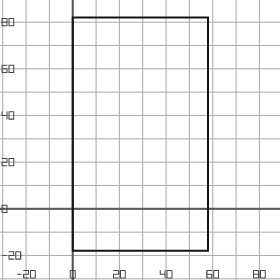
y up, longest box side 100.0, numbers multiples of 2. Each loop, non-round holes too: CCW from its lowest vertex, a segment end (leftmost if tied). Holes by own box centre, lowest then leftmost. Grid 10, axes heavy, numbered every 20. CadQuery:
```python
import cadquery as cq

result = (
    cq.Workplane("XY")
    .moveTo(0.0, -18.0)
    .lineTo(58.0, -18.0)
    .lineTo(58.0, 82.0)
    .lineTo(0.0, 82.0)
    .close()
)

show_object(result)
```